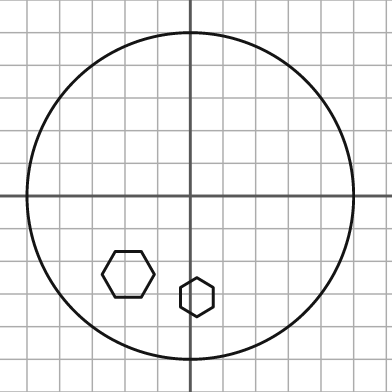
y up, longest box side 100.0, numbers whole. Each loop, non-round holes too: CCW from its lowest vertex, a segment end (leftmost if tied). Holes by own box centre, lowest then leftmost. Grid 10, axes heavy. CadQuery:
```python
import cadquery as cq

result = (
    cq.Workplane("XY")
    .moveTo(0.0, 0.0)
    .circle(50.0)
    .moveTo(2.0, -37.0)
    .lineTo(7.0, -34.0)
    .lineTo(7.0, -28.0)
    .lineTo(2.0, -25.0)
    .lineTo(-3.0, -28.0)
    .lineTo(-3.0, -34.0)
    .close()
    .moveTo(-23.0, -31.0)
    .lineTo(-15.0, -31.0)
    .lineTo(-11.0, -24.0)
    .lineTo(-15.0, -17.0)
    .lineTo(-23.0, -17.0)
    .lineTo(-27.0, -24.0)
    .close()
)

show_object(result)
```